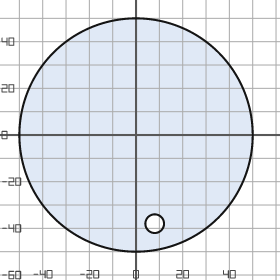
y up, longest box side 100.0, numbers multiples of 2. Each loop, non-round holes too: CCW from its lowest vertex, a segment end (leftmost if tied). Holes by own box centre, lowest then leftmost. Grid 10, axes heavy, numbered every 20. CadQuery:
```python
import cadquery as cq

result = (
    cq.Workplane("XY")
    .moveTo(0.0, 0.0)
    .circle(50.0)
    .moveTo(8.0, -38.0)
    .circle(4.0)
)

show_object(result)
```